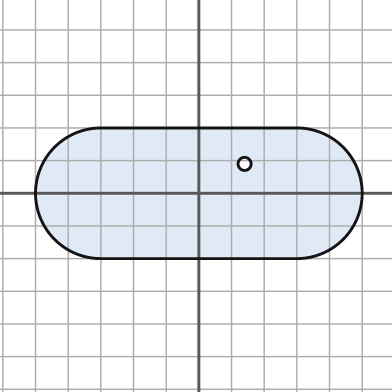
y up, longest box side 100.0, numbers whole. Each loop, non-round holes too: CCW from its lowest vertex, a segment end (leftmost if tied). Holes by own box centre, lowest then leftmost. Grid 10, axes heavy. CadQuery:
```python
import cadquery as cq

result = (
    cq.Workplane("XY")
    .moveTo(-30.0, -20.0)
    .lineTo(30.0, -20.0)
    .threePointArc((50.0, 0.0), (30.0, 20.0))
    .lineTo(-30.0, 20.0)
    .threePointArc((-50.0, 0.0), (-30.0, -20.0))
    .close()
    .moveTo(14.0, 9.0)
    .circle(2.0)
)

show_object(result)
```